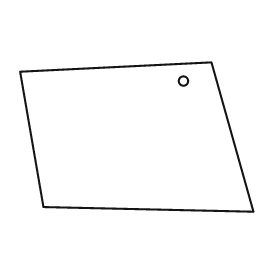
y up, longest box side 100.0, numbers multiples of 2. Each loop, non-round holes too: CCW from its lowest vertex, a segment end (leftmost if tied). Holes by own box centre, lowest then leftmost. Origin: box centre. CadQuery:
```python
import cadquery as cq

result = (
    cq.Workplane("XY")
    .moveTo(50.0, -32.0)
    .lineTo(32.0, 32.0)
    .lineTo(-50.0, 28.0)
    .lineTo(-40.0, -30.0)
    .close()
    .moveTo(20.0, 24.0)
    .circle(2.0)
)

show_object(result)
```